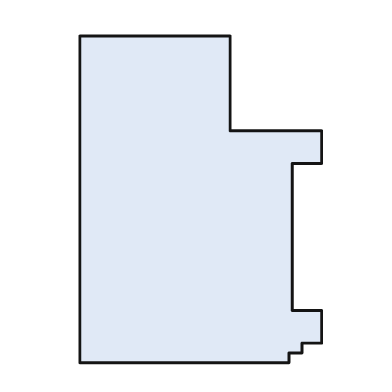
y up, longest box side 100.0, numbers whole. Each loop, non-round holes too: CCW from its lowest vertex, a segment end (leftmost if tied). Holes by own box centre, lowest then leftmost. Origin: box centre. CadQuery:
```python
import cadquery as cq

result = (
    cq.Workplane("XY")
    .moveTo(-37.0, -50.0)
    .lineTo(27.0, -50.0)
    .lineTo(27.0, -47.0)
    .lineTo(31.0, -47.0)
    .lineTo(31.0, -44.0)
    .lineTo(37.0, -44.0)
    .lineTo(37.0, -34.0)
    .lineTo(28.0, -34.0)
    .lineTo(28.0, 11.0)
    .lineTo(37.0, 11.0)
    .lineTo(37.0, 21.0)
    .lineTo(9.0, 21.0)
    .lineTo(9.0, 50.0)
    .lineTo(-37.0, 50.0)
    .close()
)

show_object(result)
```